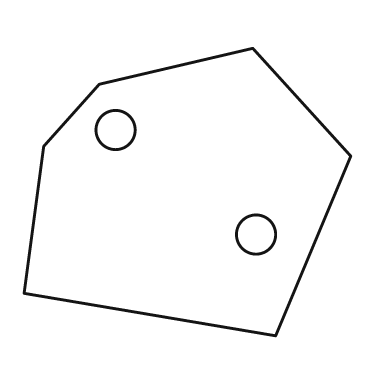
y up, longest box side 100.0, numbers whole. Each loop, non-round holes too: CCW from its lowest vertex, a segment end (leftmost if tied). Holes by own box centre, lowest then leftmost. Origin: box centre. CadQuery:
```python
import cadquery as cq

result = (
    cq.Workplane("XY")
    .moveTo(27.0, -44.0)
    .lineTo(50.0, 11.0)
    .lineTo(20.0, 44.0)
    .lineTo(-27.0, 33.0)
    .lineTo(-44.0, 14.0)
    .lineTo(-50.0, -31.0)
    .close()
    .moveTo(21.0, -13.0)
    .circle(6.0)
    .moveTo(-22.0, 19.0)
    .circle(6.0)
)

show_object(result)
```